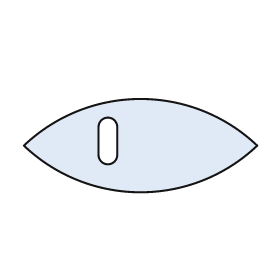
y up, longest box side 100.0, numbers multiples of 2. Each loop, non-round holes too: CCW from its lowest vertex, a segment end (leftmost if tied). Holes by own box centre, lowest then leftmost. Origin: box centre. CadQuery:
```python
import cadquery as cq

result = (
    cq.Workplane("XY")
    .moveTo(-50.0, 0.0)
    .threePointArc((0.0, -20.0), (50.0, 0.0))
    .threePointArc((0.0, 20.0), (-50.0, 0.0))
    .close()
    .moveTo(-18.0, -4.0)
    .threePointArc((-14.0, -8.0), (-10.0, -4.0))
    .lineTo(-10.0, 8.0)
    .threePointArc((-14.0, 12.0), (-18.0, 8.0))
    .close()
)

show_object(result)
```